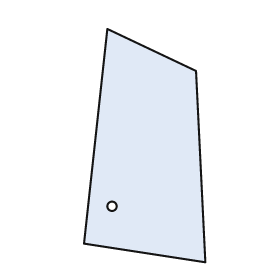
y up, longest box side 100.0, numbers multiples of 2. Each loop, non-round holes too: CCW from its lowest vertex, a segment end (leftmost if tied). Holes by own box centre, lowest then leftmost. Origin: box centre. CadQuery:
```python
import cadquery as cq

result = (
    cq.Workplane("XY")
    .moveTo(26.0, -50.0)
    .lineTo(22.0, 32.0)
    .lineTo(-16.0, 50.0)
    .lineTo(-26.0, -42.0)
    .close()
    .moveTo(-14.0, -26.0)
    .circle(2.0)
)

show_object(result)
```